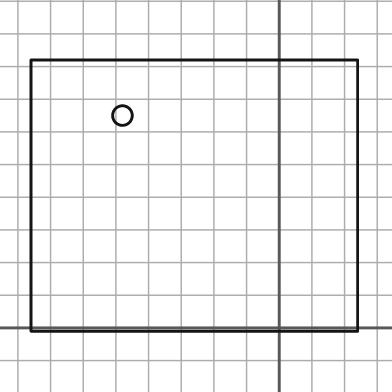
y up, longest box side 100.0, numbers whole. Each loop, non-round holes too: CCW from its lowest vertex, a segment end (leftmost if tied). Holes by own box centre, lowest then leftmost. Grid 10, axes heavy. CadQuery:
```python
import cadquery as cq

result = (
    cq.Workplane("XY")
    .moveTo(-76.0, -1.0)
    .lineTo(24.0, -1.0)
    .lineTo(24.0, 82.0)
    .lineTo(-76.0, 82.0)
    .close()
    .moveTo(-48.0, 65.0)
    .circle(3.0)
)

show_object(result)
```